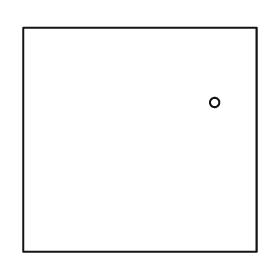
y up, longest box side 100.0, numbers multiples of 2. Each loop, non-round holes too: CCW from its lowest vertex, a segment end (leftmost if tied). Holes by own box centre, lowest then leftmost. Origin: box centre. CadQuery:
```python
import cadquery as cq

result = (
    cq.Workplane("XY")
    .moveTo(-50.0, -48.0)
    .lineTo(50.0, -48.0)
    .lineTo(50.0, 48.0)
    .lineTo(-50.0, 48.0)
    .close()
    .moveTo(32.0, 16.0)
    .circle(2.0)
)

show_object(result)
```